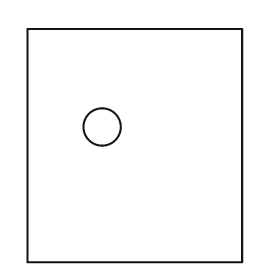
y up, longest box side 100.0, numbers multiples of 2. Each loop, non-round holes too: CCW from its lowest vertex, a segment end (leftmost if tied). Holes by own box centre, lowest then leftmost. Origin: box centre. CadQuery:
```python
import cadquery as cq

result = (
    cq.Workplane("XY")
    .moveTo(-46.0, -50.0)
    .lineTo(46.0, -50.0)
    .lineTo(46.0, 50.0)
    .lineTo(-46.0, 50.0)
    .close()
    .moveTo(-14.0, 8.0)
    .circle(8.0)
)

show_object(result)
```